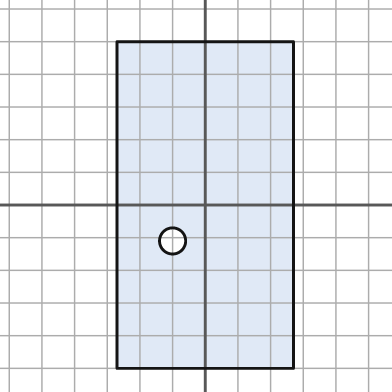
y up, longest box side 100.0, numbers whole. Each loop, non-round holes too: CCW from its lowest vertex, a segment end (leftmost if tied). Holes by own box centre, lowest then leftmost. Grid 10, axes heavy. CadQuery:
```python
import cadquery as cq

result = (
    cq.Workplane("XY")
    .moveTo(-27.0, -50.0)
    .lineTo(27.0, -50.0)
    .lineTo(27.0, 50.0)
    .lineTo(-27.0, 50.0)
    .close()
    .moveTo(-10.0, -11.0)
    .circle(4.0)
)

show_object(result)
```